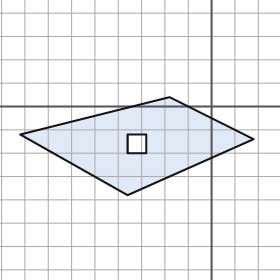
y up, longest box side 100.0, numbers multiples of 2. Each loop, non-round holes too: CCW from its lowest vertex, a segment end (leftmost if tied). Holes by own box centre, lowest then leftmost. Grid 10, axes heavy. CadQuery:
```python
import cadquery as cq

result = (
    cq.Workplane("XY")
    .moveTo(-36.0, -38.0)
    .lineTo(18.0, -14.0)
    .lineTo(-18.0, 4.0)
    .lineTo(-82.0, -12.0)
    .close()
    .moveTo(-36.0, -20.0)
    .lineTo(-28.0, -20.0)
    .lineTo(-28.0, -12.0)
    .lineTo(-36.0, -12.0)
    .close()
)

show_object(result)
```